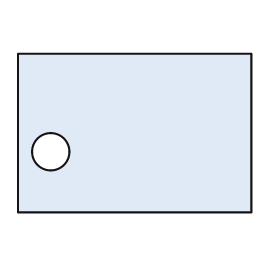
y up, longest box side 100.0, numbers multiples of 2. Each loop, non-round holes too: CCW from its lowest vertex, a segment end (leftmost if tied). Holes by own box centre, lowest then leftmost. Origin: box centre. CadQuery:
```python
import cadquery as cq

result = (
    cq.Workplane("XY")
    .moveTo(-50.0, -34.0)
    .lineTo(50.0, -34.0)
    .lineTo(50.0, 34.0)
    .lineTo(-50.0, 34.0)
    .close()
    .moveTo(-36.0, -8.0)
    .circle(8.0)
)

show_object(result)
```